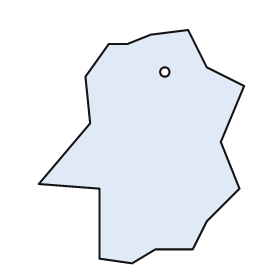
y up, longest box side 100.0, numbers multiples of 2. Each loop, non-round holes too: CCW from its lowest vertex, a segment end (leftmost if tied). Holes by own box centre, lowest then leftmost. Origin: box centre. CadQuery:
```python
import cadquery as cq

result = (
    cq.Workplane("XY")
    .moveTo(-4.0, -50.0)
    .lineTo(6.0, -44.0)
    .lineTo(22.0, -44.0)
    .lineTo(28.0, -32.0)
    .lineTo(42.0, -18.0)
    .lineTo(34.0, 2.0)
    .lineTo(44.0, 26.0)
    .lineTo(28.0, 34.0)
    .lineTo(20.0, 50.0)
    .lineTo(4.0, 48.0)
    .lineTo(-6.0, 44.0)
    .lineTo(-14.0, 44.0)
    .lineTo(-24.0, 30.0)
    .lineTo(-22.0, 10.0)
    .lineTo(-44.0, -16.0)
    .lineTo(-18.0, -18.0)
    .lineTo(-18.0, -48.0)
    .close()
    .moveTo(10.0, 32.0)
    .circle(2.0)
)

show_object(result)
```